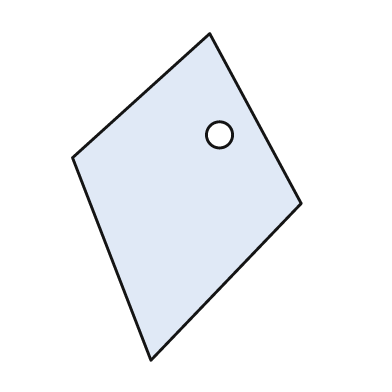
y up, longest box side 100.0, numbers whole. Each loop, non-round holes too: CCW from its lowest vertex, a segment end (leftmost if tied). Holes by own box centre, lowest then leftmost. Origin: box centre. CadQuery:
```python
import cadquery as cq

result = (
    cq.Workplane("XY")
    .moveTo(-11.0, -50.0)
    .lineTo(35.0, -2.0)
    .lineTo(7.0, 50.0)
    .lineTo(-35.0, 12.0)
    .close()
    .moveTo(10.0, 19.0)
    .circle(4.0)
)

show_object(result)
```